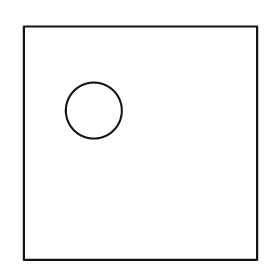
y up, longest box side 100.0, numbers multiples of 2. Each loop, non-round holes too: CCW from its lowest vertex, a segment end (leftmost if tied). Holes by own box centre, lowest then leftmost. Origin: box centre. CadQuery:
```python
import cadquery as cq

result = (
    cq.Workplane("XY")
    .moveTo(-50.0, -50.0)
    .lineTo(50.0, -50.0)
    .lineTo(50.0, 50.0)
    .lineTo(-50.0, 50.0)
    .close()
    .moveTo(-20.0, 14.0)
    .circle(12.0)
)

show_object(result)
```